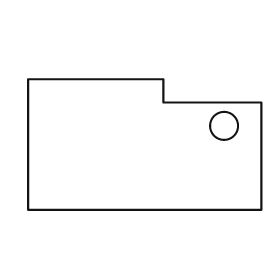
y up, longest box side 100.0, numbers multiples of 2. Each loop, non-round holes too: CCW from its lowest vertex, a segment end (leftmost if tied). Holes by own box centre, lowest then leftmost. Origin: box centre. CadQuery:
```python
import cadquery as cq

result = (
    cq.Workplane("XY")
    .moveTo(-50.0, -28.0)
    .lineTo(50.0, -28.0)
    .lineTo(50.0, 18.0)
    .lineTo(8.0, 18.0)
    .lineTo(8.0, 28.0)
    .lineTo(-50.0, 28.0)
    .close()
    .moveTo(34.0, 8.0)
    .circle(6.0)
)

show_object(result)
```